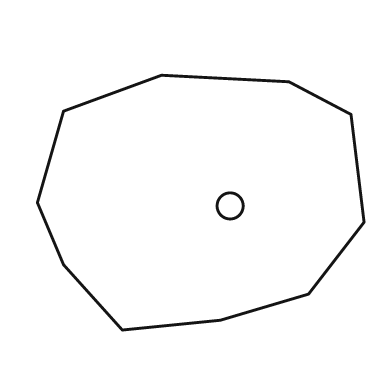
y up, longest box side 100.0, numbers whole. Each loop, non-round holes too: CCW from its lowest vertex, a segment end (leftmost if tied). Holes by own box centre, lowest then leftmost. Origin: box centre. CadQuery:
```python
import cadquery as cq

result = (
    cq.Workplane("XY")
    .moveTo(-24.0, -39.0)
    .lineTo(6.0, -36.0)
    .lineTo(33.0, -28.0)
    .lineTo(50.0, -6.0)
    .lineTo(46.0, 27.0)
    .lineTo(27.0, 37.0)
    .lineTo(-12.0, 39.0)
    .lineTo(-42.0, 28.0)
    .lineTo(-50.0, 0.0)
    .lineTo(-42.0, -19.0)
    .close()
    .moveTo(9.0, -1.0)
    .circle(4.0)
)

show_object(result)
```